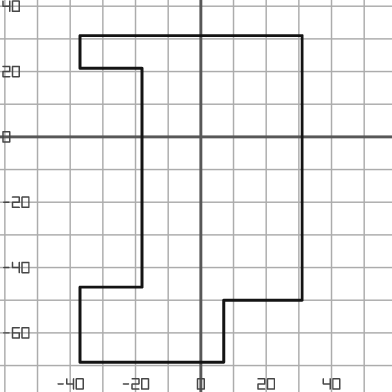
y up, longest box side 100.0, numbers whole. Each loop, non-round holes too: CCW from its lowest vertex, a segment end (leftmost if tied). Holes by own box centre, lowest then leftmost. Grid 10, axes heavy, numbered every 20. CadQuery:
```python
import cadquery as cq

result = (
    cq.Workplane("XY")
    .moveTo(-37.0, -69.0)
    .lineTo(7.0, -69.0)
    .lineTo(7.0, -50.0)
    .lineTo(31.0, -50.0)
    .lineTo(31.0, 31.0)
    .lineTo(-37.0, 31.0)
    .lineTo(-37.0, 21.0)
    .lineTo(-18.0, 21.0)
    .lineTo(-18.0, -46.0)
    .lineTo(-37.0, -46.0)
    .close()
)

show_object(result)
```